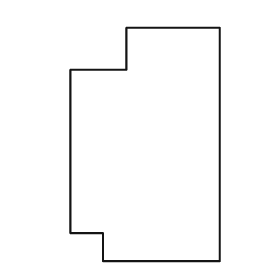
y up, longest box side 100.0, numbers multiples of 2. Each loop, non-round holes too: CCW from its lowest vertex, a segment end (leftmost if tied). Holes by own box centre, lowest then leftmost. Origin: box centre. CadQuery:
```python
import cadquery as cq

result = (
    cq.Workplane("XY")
    .moveTo(-18.0, -50.0)
    .lineTo(32.0, -50.0)
    .lineTo(32.0, 50.0)
    .lineTo(-8.0, 50.0)
    .lineTo(-8.0, 32.0)
    .lineTo(-32.0, 32.0)
    .lineTo(-32.0, -38.0)
    .lineTo(-18.0, -38.0)
    .close()
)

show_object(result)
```